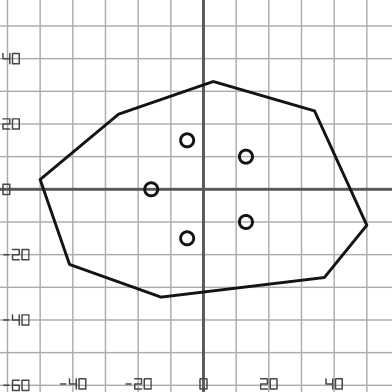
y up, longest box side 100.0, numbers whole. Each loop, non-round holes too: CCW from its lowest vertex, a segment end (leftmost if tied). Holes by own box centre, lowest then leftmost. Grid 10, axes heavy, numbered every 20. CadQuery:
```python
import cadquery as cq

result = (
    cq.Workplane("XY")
    .moveTo(-13.0, -33.0)
    .lineTo(37.0, -27.0)
    .lineTo(50.0, -11.0)
    .lineTo(34.0, 24.0)
    .lineTo(3.0, 33.0)
    .lineTo(-26.0, 23.0)
    .lineTo(-50.0, 3.0)
    .lineTo(-41.0, -23.0)
    .close()
    .moveTo(-5.0, -15.0)
    .circle(2.0)
    .moveTo(13.0, -10.0)
    .circle(2.0)
    .moveTo(-16.0, 0.0)
    .circle(2.0)
    .moveTo(13.0, 10.0)
    .circle(2.0)
    .moveTo(-5.0, 15.0)
    .circle(2.0)
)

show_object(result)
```